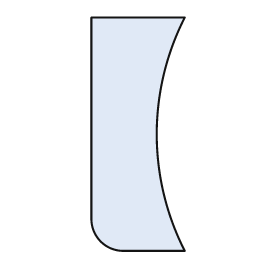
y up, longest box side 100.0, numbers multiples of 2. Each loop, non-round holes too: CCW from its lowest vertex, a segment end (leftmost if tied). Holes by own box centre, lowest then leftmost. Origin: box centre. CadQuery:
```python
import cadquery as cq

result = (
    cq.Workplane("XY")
    .moveTo(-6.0, -50.0)
    .lineTo(20.0, -50.0)
    .threePointArc((8.0, 0.0), (20.0, 50.0))
    .lineTo(-20.0, 50.0)
    .lineTo(-20.0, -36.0)
    .threePointArc((-16.0, -46.0), (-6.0, -50.0))
    .close()
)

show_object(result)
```